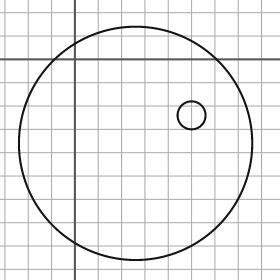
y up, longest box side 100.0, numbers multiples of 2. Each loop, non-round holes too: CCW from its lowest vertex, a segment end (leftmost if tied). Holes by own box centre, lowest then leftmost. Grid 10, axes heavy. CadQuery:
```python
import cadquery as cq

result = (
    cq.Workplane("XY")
    .moveTo(26.0, -36.0)
    .circle(50.0)
    .moveTo(50.0, -24.0)
    .circle(6.0)
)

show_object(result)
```